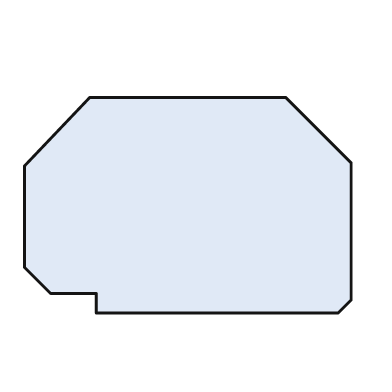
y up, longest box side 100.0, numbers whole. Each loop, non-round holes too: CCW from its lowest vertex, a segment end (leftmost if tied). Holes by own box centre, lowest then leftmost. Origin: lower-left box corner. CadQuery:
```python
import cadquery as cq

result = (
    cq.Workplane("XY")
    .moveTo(22.0, 0.0)
    .lineTo(96.0, 0.0)
    .lineTo(100.0, 4.0)
    .lineTo(100.0, 46.0)
    .lineTo(80.0, 66.0)
    .lineTo(20.0, 66.0)
    .lineTo(0.0, 45.0)
    .lineTo(0.0, 14.0)
    .lineTo(8.0, 6.0)
    .lineTo(22.0, 6.0)
    .close()
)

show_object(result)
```